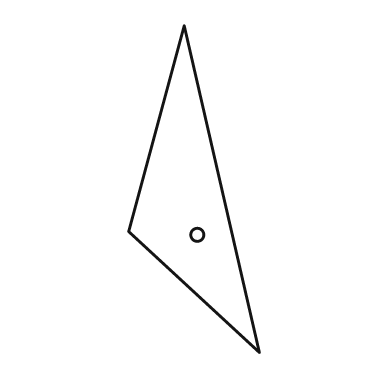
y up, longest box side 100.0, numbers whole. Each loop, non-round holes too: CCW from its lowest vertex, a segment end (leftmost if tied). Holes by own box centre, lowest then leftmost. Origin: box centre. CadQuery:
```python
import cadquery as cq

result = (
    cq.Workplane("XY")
    .moveTo(20.0, -50.0)
    .lineTo(-3.0, 50.0)
    .lineTo(-20.0, -13.0)
    .close()
    .moveTo(1.0, -14.0)
    .circle(2.0)
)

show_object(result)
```